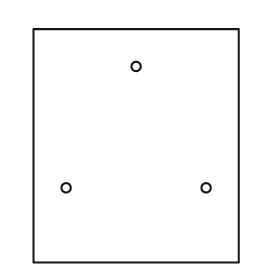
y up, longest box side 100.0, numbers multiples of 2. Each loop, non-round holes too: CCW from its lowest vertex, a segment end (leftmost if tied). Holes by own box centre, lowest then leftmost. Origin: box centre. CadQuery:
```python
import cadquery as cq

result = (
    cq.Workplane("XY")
    .moveTo(-44.0, -50.0)
    .lineTo(44.0, -50.0)
    .lineTo(44.0, 50.0)
    .lineTo(-44.0, 50.0)
    .close()
    .moveTo(-30.0, -18.0)
    .circle(2.0)
    .moveTo(30.0, -18.0)
    .circle(2.0)
    .moveTo(0.0, 34.0)
    .circle(2.0)
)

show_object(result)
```